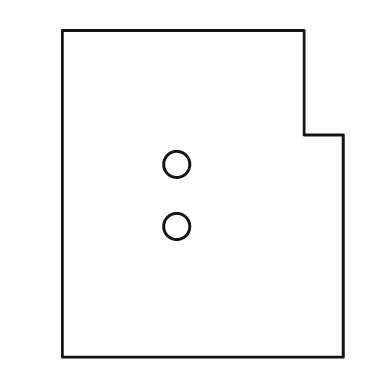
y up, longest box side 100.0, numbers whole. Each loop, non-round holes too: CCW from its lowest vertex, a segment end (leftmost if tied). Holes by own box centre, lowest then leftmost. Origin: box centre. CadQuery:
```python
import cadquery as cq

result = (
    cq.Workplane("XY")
    .moveTo(-43.0, -50.0)
    .lineTo(43.0, -50.0)
    .lineTo(43.0, 18.0)
    .lineTo(31.0, 18.0)
    .lineTo(31.0, 50.0)
    .lineTo(-43.0, 50.0)
    .close()
    .moveTo(-8.0, -10.0)
    .circle(4.0)
    .moveTo(-8.0, 9.0)
    .circle(4.0)
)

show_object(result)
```